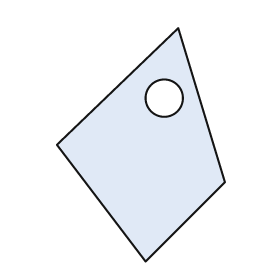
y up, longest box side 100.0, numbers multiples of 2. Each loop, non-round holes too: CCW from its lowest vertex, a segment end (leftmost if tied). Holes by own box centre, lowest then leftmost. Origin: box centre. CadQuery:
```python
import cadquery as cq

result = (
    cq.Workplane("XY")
    .moveTo(2.0, -50.0)
    .lineTo(36.0, -16.0)
    .lineTo(16.0, 50.0)
    .lineTo(-36.0, 0.0)
    .close()
    .moveTo(10.0, 20.0)
    .circle(8.0)
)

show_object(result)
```